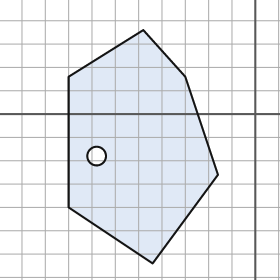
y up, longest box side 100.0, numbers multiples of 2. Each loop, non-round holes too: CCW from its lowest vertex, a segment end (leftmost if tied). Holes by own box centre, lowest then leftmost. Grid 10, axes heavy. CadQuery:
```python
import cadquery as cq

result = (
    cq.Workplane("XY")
    .moveTo(-44.0, -64.0)
    .lineTo(-16.0, -26.0)
    .lineTo(-30.0, 16.0)
    .lineTo(-48.0, 36.0)
    .lineTo(-80.0, 16.0)
    .lineTo(-80.0, -40.0)
    .close()
    .moveTo(-68.0, -18.0)
    .circle(4.0)
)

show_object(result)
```